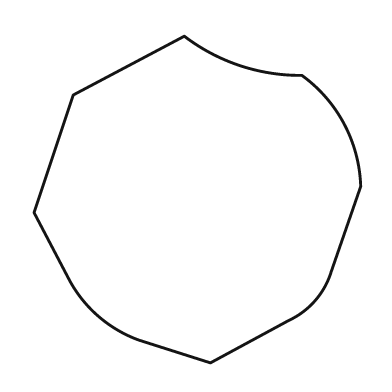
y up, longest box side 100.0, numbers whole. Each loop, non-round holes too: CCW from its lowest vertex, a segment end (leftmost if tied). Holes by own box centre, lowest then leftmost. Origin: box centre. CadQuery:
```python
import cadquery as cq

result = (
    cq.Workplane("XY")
    .moveTo(4.0, -50.0)
    .lineTo(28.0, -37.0)
    .threePointArc((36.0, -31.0), (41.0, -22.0))
    .lineTo(50.0, 4.0)
    .threePointArc((45.0, 23.0), (32.0, 38.0))
    .threePointArc((13.0, 41.0), (-4.0, 50.0))
    .lineTo(-38.0, 32.0)
    .lineTo(-50.0, -4.0)
    .lineTo(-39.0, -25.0)
    .threePointArc((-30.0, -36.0), (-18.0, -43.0))
    .close()
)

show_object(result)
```